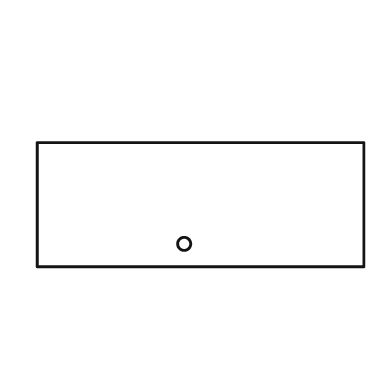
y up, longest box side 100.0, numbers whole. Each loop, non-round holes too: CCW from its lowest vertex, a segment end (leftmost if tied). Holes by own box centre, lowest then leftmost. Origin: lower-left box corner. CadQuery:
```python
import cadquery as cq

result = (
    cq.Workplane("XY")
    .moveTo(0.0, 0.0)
    .lineTo(100.0, 0.0)
    .lineTo(100.0, 38.0)
    .lineTo(0.0, 38.0)
    .close()
    .moveTo(45.0, 7.0)
    .circle(2.0)
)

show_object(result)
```